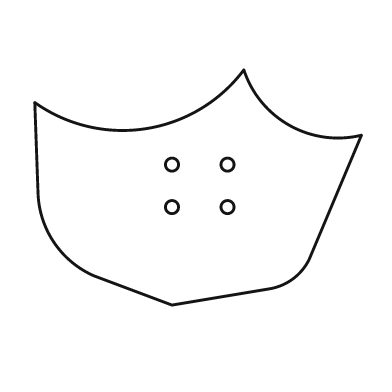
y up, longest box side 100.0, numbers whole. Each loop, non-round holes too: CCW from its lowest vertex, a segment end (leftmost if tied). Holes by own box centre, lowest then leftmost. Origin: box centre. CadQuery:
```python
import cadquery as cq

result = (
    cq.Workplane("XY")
    .moveTo(-8.0, -36.0)
    .lineTo(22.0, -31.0)
    .threePointArc((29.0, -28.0), (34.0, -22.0))
    .lineTo(50.0, 16.0)
    .threePointArc((28.0, 19.0), (14.0, 36.0))
    .threePointArc((-16.0, 18.0), (-50.0, 26.0))
    .lineTo(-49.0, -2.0)
    .threePointArc((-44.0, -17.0), (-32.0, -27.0))
    .close()
    .moveTo(-8.0, -6.0)
    .circle(2.0)
    .moveTo(9.0, -6.0)
    .circle(2.0)
    .moveTo(-8.0, 7.0)
    .circle(2.0)
    .moveTo(9.0, 7.0)
    .circle(2.0)
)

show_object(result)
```